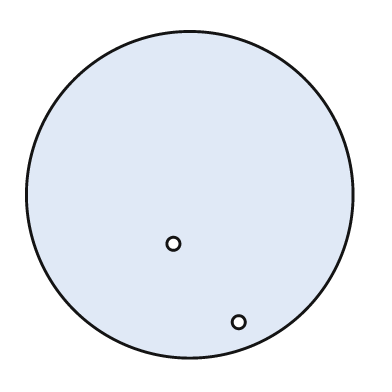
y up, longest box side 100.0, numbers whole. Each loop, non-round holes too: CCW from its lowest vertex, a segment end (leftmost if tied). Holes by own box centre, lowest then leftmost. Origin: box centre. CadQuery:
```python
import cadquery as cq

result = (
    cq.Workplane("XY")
    .moveTo(0.0, 0.0)
    .circle(50.0)
    .moveTo(15.0, -39.0)
    .circle(2.0)
    .moveTo(-5.0, -15.0)
    .circle(2.0)
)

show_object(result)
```